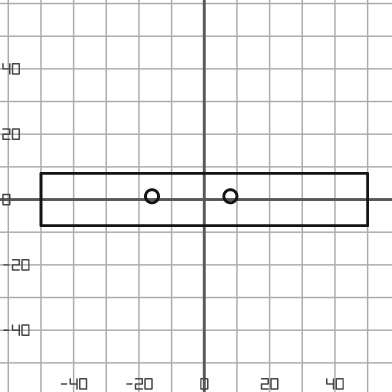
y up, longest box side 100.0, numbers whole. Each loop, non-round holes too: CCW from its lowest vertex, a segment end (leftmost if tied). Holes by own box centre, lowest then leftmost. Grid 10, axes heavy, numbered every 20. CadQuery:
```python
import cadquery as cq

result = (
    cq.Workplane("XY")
    .moveTo(-50.0, -8.0)
    .lineTo(50.0, -8.0)
    .lineTo(50.0, 8.0)
    .lineTo(-50.0, 8.0)
    .close()
    .moveTo(-16.0, 1.0)
    .circle(2.0)
    .moveTo(8.0, 1.0)
    .circle(2.0)
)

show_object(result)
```